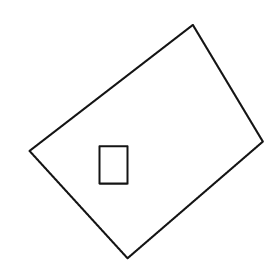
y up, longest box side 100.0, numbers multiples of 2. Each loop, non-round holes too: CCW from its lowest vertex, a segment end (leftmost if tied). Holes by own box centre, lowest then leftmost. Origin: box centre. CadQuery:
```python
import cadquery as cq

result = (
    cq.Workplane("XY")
    .moveTo(-8.0, -50.0)
    .lineTo(50.0, 0.0)
    .lineTo(20.0, 50.0)
    .lineTo(-50.0, -4.0)
    .close()
    .moveTo(-20.0, -18.0)
    .lineTo(-8.0, -18.0)
    .lineTo(-8.0, -2.0)
    .lineTo(-20.0, -2.0)
    .close()
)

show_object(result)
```